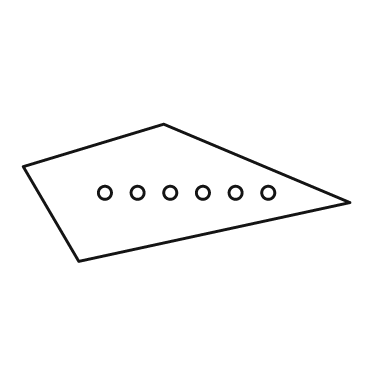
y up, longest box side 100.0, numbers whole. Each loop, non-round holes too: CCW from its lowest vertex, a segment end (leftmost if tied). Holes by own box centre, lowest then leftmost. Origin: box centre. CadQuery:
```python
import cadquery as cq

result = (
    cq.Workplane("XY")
    .moveTo(-33.0, -21.0)
    .lineTo(50.0, -3.0)
    .lineTo(-7.0, 21.0)
    .lineTo(-50.0, 8.0)
    .close()
    .moveTo(-25.0, 0.0)
    .circle(2.0)
    .moveTo(-15.0, 0.0)
    .circle(2.0)
    .moveTo(-5.0, 0.0)
    .circle(2.0)
    .moveTo(5.0, 0.0)
    .circle(2.0)
    .moveTo(15.0, 0.0)
    .circle(2.0)
    .moveTo(25.0, 0.0)
    .circle(2.0)
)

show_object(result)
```